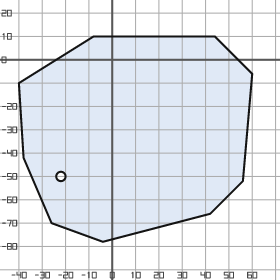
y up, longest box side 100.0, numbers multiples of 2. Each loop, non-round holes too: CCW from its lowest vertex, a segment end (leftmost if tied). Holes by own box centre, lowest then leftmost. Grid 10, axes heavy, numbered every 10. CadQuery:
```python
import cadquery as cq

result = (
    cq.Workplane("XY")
    .moveTo(-4.0, -78.0)
    .lineTo(42.0, -66.0)
    .lineTo(56.0, -52.0)
    .lineTo(60.0, -6.0)
    .lineTo(44.0, 10.0)
    .lineTo(-8.0, 10.0)
    .lineTo(-40.0, -10.0)
    .lineTo(-38.0, -42.0)
    .lineTo(-26.0, -70.0)
    .close()
    .moveTo(-22.0, -50.0)
    .circle(2.0)
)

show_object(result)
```